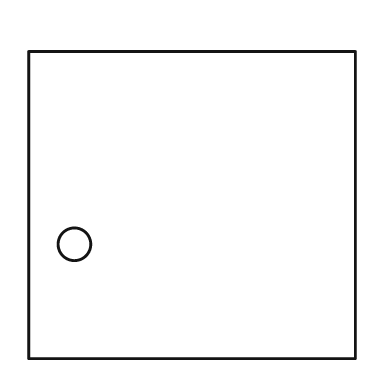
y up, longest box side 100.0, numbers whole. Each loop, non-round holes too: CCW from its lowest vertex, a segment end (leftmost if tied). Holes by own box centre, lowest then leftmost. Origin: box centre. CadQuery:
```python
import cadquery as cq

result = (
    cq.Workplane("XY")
    .moveTo(-50.0, -47.0)
    .lineTo(50.0, -47.0)
    .lineTo(50.0, 47.0)
    .lineTo(-50.0, 47.0)
    .close()
    .moveTo(-36.0, -12.0)
    .circle(5.0)
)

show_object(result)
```